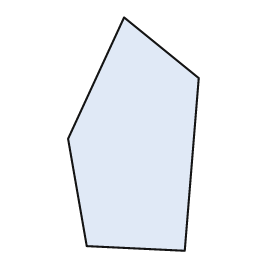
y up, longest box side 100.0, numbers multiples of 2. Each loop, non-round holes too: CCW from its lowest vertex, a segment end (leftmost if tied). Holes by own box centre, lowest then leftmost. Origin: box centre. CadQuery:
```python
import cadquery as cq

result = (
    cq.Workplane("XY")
    .moveTo(22.0, -50.0)
    .lineTo(28.0, 24.0)
    .lineTo(-4.0, 50.0)
    .lineTo(-28.0, -2.0)
    .lineTo(-20.0, -48.0)
    .close()
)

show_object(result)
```